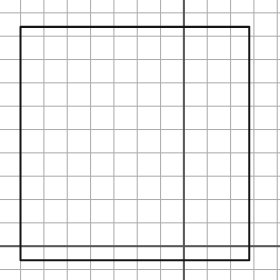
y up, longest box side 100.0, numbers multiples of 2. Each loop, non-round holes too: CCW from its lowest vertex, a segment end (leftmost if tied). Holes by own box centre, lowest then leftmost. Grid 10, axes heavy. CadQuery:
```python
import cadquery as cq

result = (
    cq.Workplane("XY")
    .moveTo(-70.0, -6.0)
    .lineTo(28.0, -6.0)
    .lineTo(28.0, 94.0)
    .lineTo(-70.0, 94.0)
    .close()
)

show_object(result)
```